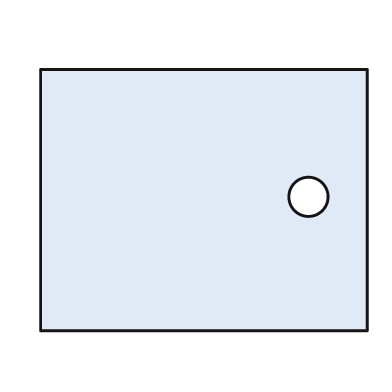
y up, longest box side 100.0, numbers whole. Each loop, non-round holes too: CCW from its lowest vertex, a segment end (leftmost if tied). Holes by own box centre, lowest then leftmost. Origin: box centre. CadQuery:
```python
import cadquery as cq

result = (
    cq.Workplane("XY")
    .moveTo(-50.0, -40.0)
    .lineTo(50.0, -40.0)
    .lineTo(50.0, 40.0)
    .lineTo(-50.0, 40.0)
    .close()
    .moveTo(32.0, 1.0)
    .circle(6.0)
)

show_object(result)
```